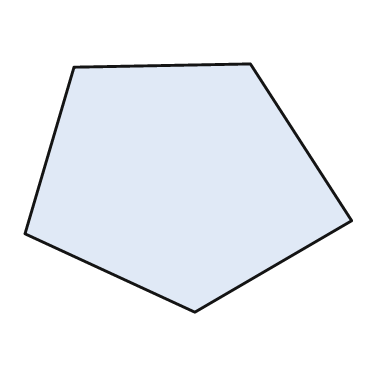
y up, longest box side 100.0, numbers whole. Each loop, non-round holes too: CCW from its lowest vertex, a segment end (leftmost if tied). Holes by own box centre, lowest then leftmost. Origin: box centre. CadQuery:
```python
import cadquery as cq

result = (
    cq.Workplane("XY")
    .moveTo(2.0, -38.0)
    .lineTo(50.0, -10.0)
    .lineTo(19.0, 38.0)
    .lineTo(-35.0, 37.0)
    .lineTo(-50.0, -14.0)
    .close()
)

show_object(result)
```